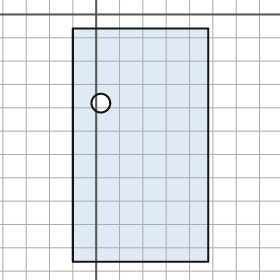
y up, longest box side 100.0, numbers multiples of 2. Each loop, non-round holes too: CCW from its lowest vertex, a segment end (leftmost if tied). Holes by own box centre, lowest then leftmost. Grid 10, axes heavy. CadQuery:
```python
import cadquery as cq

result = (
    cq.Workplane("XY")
    .moveTo(-10.0, -106.0)
    .lineTo(48.0, -106.0)
    .lineTo(48.0, -6.0)
    .lineTo(-10.0, -6.0)
    .close()
    .moveTo(2.0, -38.0)
    .circle(4.0)
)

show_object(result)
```